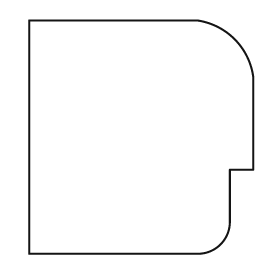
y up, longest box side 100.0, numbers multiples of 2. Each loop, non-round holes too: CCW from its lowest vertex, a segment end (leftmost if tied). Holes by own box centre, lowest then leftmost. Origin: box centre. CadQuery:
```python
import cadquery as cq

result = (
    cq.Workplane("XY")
    .moveTo(-48.0, -50.0)
    .lineTo(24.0, -50.0)
    .threePointArc((34.0, -46.0), (38.0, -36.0))
    .lineTo(38.0, -14.0)
    .lineTo(48.0, -14.0)
    .lineTo(48.0, 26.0)
    .threePointArc((40.0, 42.0), (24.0, 50.0))
    .lineTo(-48.0, 50.0)
    .close()
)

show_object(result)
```